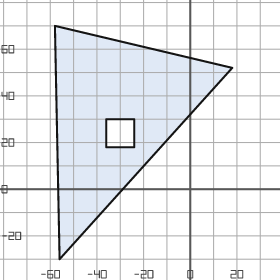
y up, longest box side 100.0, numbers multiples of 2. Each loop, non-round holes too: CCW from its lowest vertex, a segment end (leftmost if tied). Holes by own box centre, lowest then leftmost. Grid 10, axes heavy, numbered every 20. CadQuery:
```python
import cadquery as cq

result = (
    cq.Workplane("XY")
    .moveTo(-56.0, -30.0)
    .lineTo(18.0, 52.0)
    .lineTo(-58.0, 70.0)
    .close()
    .moveTo(-36.0, 18.0)
    .lineTo(-24.0, 18.0)
    .lineTo(-24.0, 30.0)
    .lineTo(-36.0, 30.0)
    .close()
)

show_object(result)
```